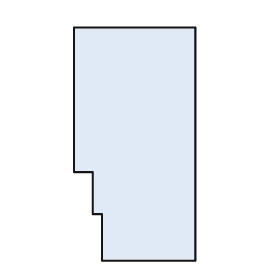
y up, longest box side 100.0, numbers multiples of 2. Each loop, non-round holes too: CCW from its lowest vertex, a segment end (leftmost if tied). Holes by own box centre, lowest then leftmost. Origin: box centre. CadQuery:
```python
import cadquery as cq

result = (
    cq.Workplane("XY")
    .moveTo(-14.0, -50.0)
    .lineTo(26.0, -50.0)
    .lineTo(26.0, 50.0)
    .lineTo(-26.0, 50.0)
    .lineTo(-26.0, -12.0)
    .lineTo(-18.0, -12.0)
    .lineTo(-18.0, -30.0)
    .lineTo(-14.0, -30.0)
    .close()
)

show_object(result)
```